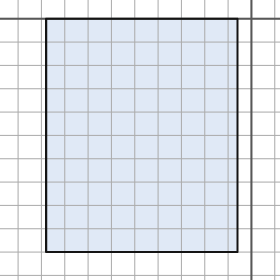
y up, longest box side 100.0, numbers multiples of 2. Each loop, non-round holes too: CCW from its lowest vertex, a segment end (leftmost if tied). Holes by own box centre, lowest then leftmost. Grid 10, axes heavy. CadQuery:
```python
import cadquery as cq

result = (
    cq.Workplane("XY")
    .moveTo(-88.0, -100.0)
    .lineTo(-6.0, -100.0)
    .lineTo(-6.0, 0.0)
    .lineTo(-88.0, 0.0)
    .close()
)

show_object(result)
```